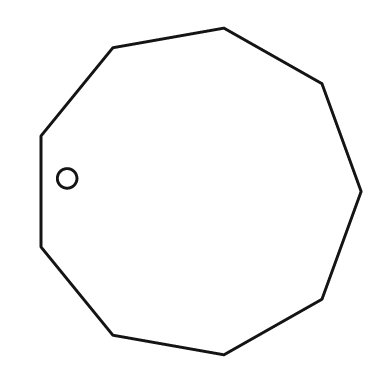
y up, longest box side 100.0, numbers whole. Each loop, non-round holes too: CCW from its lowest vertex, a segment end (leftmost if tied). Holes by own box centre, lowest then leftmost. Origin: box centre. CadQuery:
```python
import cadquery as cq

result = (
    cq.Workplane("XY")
    .moveTo(7.0, -50.0)
    .lineTo(37.0, -33.0)
    .lineTo(49.0, 0.0)
    .lineTo(37.0, 33.0)
    .lineTo(7.0, 50.0)
    .lineTo(-27.0, 44.0)
    .lineTo(-49.0, 17.0)
    .lineTo(-49.0, -17.0)
    .lineTo(-27.0, -44.0)
    .close()
    .moveTo(-41.0, 4.0)
    .circle(3.0)
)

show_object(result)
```